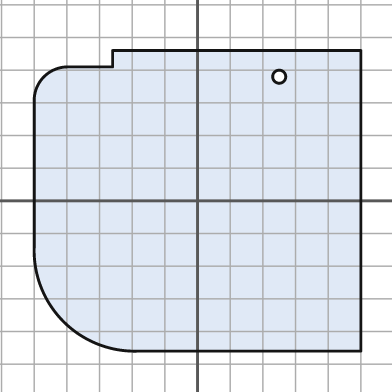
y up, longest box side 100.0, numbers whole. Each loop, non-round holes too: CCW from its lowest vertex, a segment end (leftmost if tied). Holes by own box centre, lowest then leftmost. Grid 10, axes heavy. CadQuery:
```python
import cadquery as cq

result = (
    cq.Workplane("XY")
    .moveTo(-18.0, -46.0)
    .lineTo(50.0, -46.0)
    .lineTo(50.0, 46.0)
    .lineTo(-26.0, 46.0)
    .lineTo(-26.0, 41.0)
    .lineTo(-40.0, 41.0)
    .threePointArc((-47.0, 38.0), (-50.0, 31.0))
    .lineTo(-50.0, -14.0)
    .threePointArc((-41.0, -37.0), (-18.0, -46.0))
    .close()
    .moveTo(25.0, 38.0)
    .circle(2.0)
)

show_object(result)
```